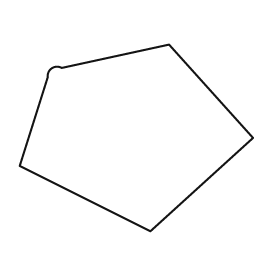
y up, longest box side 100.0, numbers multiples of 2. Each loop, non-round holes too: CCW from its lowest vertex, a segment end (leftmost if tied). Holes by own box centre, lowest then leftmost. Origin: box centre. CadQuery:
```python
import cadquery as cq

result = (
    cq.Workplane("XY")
    .moveTo(6.0, -40.0)
    .lineTo(50.0, 0.0)
    .lineTo(14.0, 40.0)
    .lineTo(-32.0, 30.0)
    .threePointArc((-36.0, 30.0), (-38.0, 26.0))
    .lineTo(-50.0, -12.0)
    .close()
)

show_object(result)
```